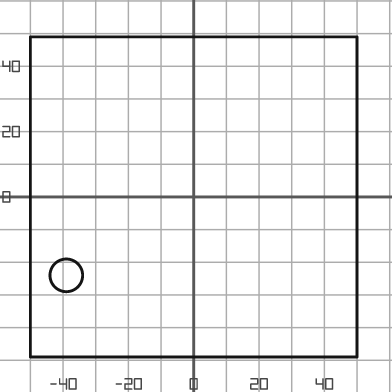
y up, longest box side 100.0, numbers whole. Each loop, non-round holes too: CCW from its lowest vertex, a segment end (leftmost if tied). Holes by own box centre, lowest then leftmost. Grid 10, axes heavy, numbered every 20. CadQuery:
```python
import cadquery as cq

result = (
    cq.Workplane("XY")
    .moveTo(-50.0, -49.0)
    .lineTo(50.0, -49.0)
    .lineTo(50.0, 49.0)
    .lineTo(-50.0, 49.0)
    .close()
    .moveTo(-39.0, -24.0)
    .circle(5.0)
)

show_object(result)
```